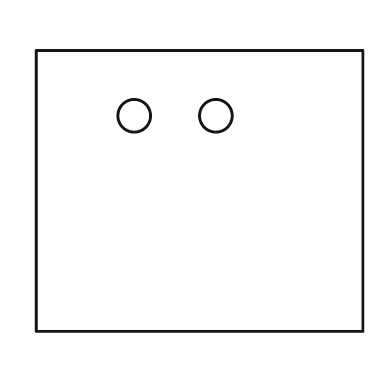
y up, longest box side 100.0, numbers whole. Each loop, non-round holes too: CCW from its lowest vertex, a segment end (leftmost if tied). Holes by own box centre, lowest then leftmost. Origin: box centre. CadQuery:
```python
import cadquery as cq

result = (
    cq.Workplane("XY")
    .moveTo(-50.0, -43.0)
    .lineTo(50.0, -43.0)
    .lineTo(50.0, 43.0)
    .lineTo(-50.0, 43.0)
    .close()
    .moveTo(-20.0, 23.0)
    .circle(5.0)
    .moveTo(5.0, 23.0)
    .circle(5.0)
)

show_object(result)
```